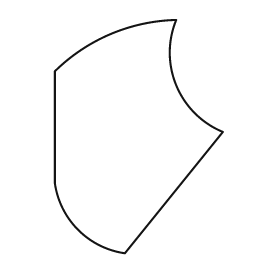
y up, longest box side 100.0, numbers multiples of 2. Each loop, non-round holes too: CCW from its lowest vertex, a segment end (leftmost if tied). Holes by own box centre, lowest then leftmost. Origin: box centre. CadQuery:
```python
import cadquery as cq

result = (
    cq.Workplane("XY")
    .moveTo(-6.0, -50.0)
    .lineTo(36.0, 2.0)
    .threePointArc((16.0, 22.0), (16.0, 50.0))
    .threePointArc((-12.0, 44.0), (-36.0, 28.0))
    .lineTo(-36.0, -20.0)
    .threePointArc((-26.0, -40.0), (-6.0, -50.0))
    .close()
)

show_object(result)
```